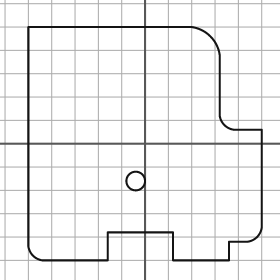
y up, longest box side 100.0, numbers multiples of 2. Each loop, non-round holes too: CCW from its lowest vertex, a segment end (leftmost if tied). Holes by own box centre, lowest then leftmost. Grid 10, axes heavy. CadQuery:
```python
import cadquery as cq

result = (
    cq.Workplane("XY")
    .moveTo(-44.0, -50.0)
    .lineTo(-16.0, -50.0)
    .lineTo(-16.0, -38.0)
    .lineTo(12.0, -38.0)
    .lineTo(12.0, -50.0)
    .lineTo(36.0, -50.0)
    .lineTo(36.0, -42.0)
    .lineTo(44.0, -42.0)
    .threePointArc((48.0, -40.0), (50.0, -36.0))
    .lineTo(50.0, 6.0)
    .lineTo(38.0, 6.0)
    .threePointArc((34.0, 8.0), (32.0, 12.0))
    .lineTo(32.0, 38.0)
    .threePointArc((28.0, 46.0), (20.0, 50.0))
    .lineTo(-50.0, 50.0)
    .lineTo(-50.0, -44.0)
    .threePointArc((-48.0, -48.0), (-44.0, -50.0))
    .close()
    .moveTo(-4.0, -16.0)
    .circle(4.0)
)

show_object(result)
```